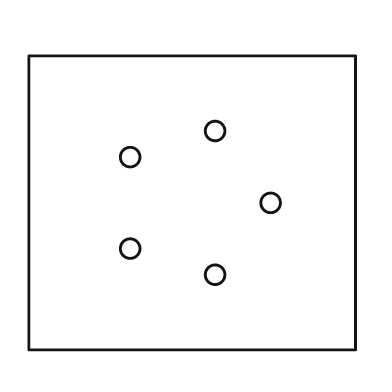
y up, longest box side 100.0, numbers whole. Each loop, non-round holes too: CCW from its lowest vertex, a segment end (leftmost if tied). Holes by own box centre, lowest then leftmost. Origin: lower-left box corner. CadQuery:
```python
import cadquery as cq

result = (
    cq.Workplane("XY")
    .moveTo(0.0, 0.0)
    .lineTo(100.0, 0.0)
    .lineTo(100.0, 90.0)
    .lineTo(0.0, 90.0)
    .close()
    .moveTo(57.0, 23.0)
    .circle(3.0)
    .moveTo(31.0, 31.0)
    .circle(3.0)
    .moveTo(74.0, 45.0)
    .circle(3.0)
    .moveTo(31.0, 59.0)
    .circle(3.0)
    .moveTo(57.0, 67.0)
    .circle(3.0)
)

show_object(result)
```